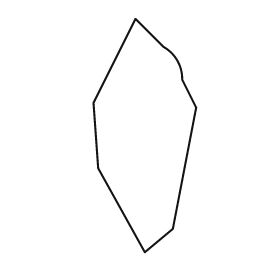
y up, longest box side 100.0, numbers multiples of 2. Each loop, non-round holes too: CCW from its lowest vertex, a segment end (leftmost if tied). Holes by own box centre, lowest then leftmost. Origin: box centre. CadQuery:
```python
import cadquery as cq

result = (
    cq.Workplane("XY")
    .moveTo(0.0, -50.0)
    .lineTo(12.0, -40.0)
    .lineTo(22.0, 12.0)
    .lineTo(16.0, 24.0)
    .threePointArc((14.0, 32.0), (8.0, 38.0))
    .lineTo(-4.0, 50.0)
    .lineTo(-22.0, 14.0)
    .lineTo(-20.0, -14.0)
    .close()
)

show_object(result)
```